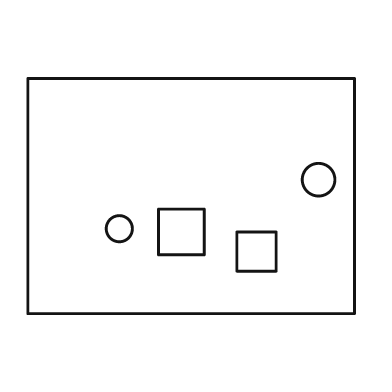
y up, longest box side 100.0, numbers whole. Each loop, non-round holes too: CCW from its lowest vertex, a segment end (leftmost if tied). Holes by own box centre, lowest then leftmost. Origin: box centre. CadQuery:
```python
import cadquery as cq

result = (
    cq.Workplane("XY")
    .moveTo(-50.0, -36.0)
    .lineTo(50.0, -36.0)
    .lineTo(50.0, 36.0)
    .lineTo(-50.0, 36.0)
    .close()
    .moveTo(14.0, -23.0)
    .lineTo(26.0, -23.0)
    .lineTo(26.0, -11.0)
    .lineTo(14.0, -11.0)
    .close()
    .moveTo(-10.0, -18.0)
    .lineTo(4.0, -18.0)
    .lineTo(4.0, -4.0)
    .lineTo(-10.0, -4.0)
    .close()
    .moveTo(-22.0, -10.0)
    .circle(4.0)
    .moveTo(39.0, 5.0)
    .circle(5.0)
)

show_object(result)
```